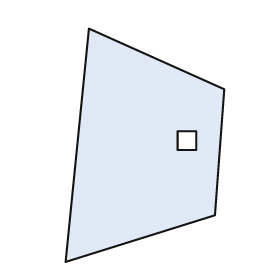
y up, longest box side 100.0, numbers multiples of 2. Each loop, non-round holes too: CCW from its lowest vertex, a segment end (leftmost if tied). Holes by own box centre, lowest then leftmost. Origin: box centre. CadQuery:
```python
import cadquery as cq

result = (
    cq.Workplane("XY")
    .moveTo(-34.0, -50.0)
    .lineTo(30.0, -30.0)
    .lineTo(34.0, 24.0)
    .lineTo(-24.0, 50.0)
    .close()
    .moveTo(14.0, -2.0)
    .lineTo(22.0, -2.0)
    .lineTo(22.0, 6.0)
    .lineTo(14.0, 6.0)
    .close()
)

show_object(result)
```